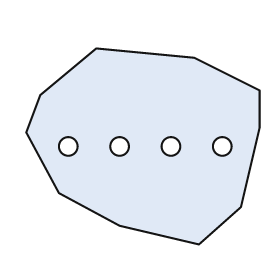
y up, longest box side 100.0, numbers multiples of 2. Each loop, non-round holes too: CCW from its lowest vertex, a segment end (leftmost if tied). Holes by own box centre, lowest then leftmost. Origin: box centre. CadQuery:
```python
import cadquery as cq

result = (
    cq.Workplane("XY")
    .moveTo(24.0, -42.0)
    .lineTo(42.0, -26.0)
    .lineTo(50.0, 8.0)
    .lineTo(50.0, 24.0)
    .lineTo(22.0, 38.0)
    .lineTo(-20.0, 42.0)
    .lineTo(-44.0, 22.0)
    .lineTo(-50.0, 6.0)
    .lineTo(-36.0, -20.0)
    .lineTo(-10.0, -34.0)
    .close()
    .moveTo(-32.0, 0.0)
    .circle(4.0)
    .moveTo(-10.0, 0.0)
    .circle(4.0)
    .moveTo(12.0, 0.0)
    .circle(4.0)
    .moveTo(34.0, 0.0)
    .circle(4.0)
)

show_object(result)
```